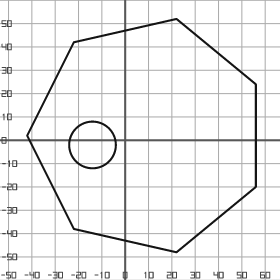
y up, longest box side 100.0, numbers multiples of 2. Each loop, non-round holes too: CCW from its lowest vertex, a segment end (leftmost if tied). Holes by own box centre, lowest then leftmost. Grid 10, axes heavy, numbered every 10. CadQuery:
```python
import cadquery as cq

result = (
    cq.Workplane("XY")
    .moveTo(22.0, -48.0)
    .lineTo(56.0, -20.0)
    .lineTo(56.0, 24.0)
    .lineTo(22.0, 52.0)
    .lineTo(-22.0, 42.0)
    .lineTo(-42.0, 2.0)
    .lineTo(-22.0, -38.0)
    .close()
    .moveTo(-14.0, -2.0)
    .circle(10.0)
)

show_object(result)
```